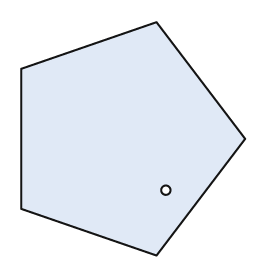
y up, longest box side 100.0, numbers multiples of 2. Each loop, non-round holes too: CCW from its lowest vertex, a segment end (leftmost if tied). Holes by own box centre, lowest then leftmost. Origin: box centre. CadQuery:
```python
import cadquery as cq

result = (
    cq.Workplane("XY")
    .moveTo(10.0, -50.0)
    .lineTo(48.0, 0.0)
    .lineTo(10.0, 50.0)
    .lineTo(-48.0, 30.0)
    .lineTo(-48.0, -30.0)
    .close()
    .moveTo(14.0, -22.0)
    .circle(2.0)
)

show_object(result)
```